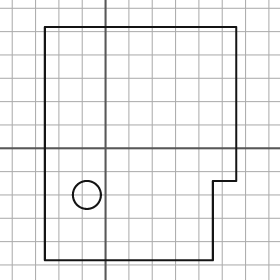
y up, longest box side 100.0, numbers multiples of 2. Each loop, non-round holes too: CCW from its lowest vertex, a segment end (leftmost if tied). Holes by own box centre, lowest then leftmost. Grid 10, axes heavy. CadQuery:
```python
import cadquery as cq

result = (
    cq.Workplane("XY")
    .moveTo(-26.0, -48.0)
    .lineTo(46.0, -48.0)
    .lineTo(46.0, -14.0)
    .lineTo(56.0, -14.0)
    .lineTo(56.0, 52.0)
    .lineTo(-26.0, 52.0)
    .close()
    .moveTo(-8.0, -20.0)
    .circle(6.0)
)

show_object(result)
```